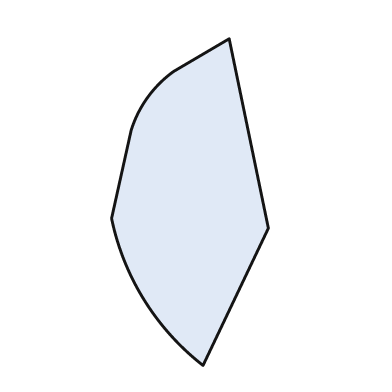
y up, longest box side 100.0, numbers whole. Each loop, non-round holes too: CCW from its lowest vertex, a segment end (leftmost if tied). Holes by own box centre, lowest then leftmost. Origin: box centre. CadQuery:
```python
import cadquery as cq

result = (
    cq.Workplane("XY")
    .moveTo(4.0, -50.0)
    .lineTo(24.0, -8.0)
    .lineTo(12.0, 50.0)
    .lineTo(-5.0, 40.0)
    .threePointArc((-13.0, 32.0), (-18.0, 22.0))
    .lineTo(-24.0, -5.0)
    .threePointArc((-14.0, -30.0), (4.0, -50.0))
    .close()
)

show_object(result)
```